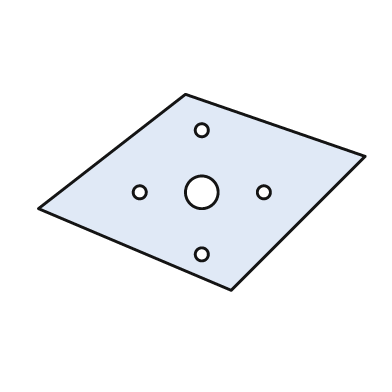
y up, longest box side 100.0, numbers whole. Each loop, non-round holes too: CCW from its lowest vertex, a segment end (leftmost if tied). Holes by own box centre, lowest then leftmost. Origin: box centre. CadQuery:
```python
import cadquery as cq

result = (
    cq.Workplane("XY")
    .moveTo(9.0, -30.0)
    .lineTo(50.0, 11.0)
    .lineTo(-5.0, 30.0)
    .lineTo(-50.0, -5.0)
    .close()
    .moveTo(0.0, -19.0)
    .circle(2.0)
    .moveTo(-19.0, 0.0)
    .circle(2.0)
    .moveTo(0.0, 0.0)
    .circle(5.0)
    .moveTo(19.0, 0.0)
    .circle(2.0)
    .moveTo(0.0, 19.0)
    .circle(2.0)
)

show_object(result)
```